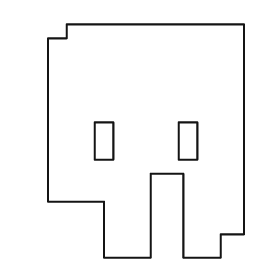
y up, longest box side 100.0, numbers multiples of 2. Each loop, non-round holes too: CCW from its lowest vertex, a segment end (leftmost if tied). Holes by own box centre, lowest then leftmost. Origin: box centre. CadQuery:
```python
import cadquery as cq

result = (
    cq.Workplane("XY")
    .moveTo(-18.0, -50.0)
    .lineTo(2.0, -50.0)
    .lineTo(2.0, -14.0)
    .lineTo(16.0, -14.0)
    .lineTo(16.0, -50.0)
    .lineTo(32.0, -50.0)
    .lineTo(32.0, -40.0)
    .lineTo(42.0, -40.0)
    .lineTo(42.0, 50.0)
    .lineTo(-34.0, 50.0)
    .lineTo(-34.0, 44.0)
    .lineTo(-42.0, 44.0)
    .lineTo(-42.0, -26.0)
    .lineTo(-18.0, -26.0)
    .close()
    .moveTo(-22.0, -8.0)
    .lineTo(-14.0, -8.0)
    .lineTo(-14.0, 8.0)
    .lineTo(-22.0, 8.0)
    .close()
    .moveTo(14.0, -8.0)
    .lineTo(22.0, -8.0)
    .lineTo(22.0, 8.0)
    .lineTo(14.0, 8.0)
    .close()
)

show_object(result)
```